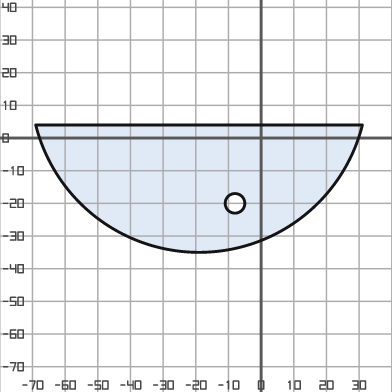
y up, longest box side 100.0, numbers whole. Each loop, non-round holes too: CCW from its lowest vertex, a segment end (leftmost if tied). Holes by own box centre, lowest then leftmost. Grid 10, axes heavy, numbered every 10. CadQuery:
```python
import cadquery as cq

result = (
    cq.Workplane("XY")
    .moveTo(-69.0, 4.0)
    .threePointArc((-19.0, -35.0), (31.0, 4.0))
    .close()
    .moveTo(-8.0, -20.0)
    .circle(3.0)
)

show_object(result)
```